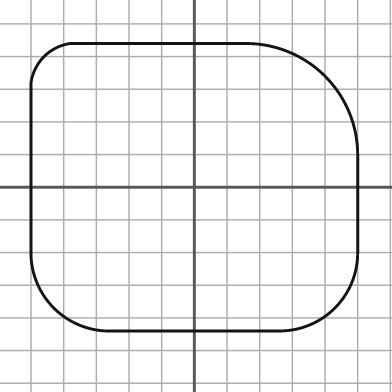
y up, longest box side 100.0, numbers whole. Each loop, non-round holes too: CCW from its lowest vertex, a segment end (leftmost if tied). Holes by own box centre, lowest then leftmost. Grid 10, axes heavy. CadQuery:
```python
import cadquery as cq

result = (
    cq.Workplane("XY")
    .moveTo(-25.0, -44.0)
    .lineTo(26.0, -44.0)
    .threePointArc((43.0, -37.0), (50.0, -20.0))
    .lineTo(50.0, 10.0)
    .threePointArc((40.0, 34.0), (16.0, 44.0))
    .lineTo(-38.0, 44.0)
    .threePointArc((-46.0, 40.0), (-50.0, 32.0))
    .lineTo(-50.0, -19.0)
    .threePointArc((-43.0, -37.0), (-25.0, -44.0))
    .close()
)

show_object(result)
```